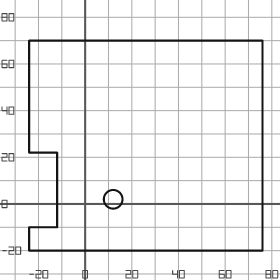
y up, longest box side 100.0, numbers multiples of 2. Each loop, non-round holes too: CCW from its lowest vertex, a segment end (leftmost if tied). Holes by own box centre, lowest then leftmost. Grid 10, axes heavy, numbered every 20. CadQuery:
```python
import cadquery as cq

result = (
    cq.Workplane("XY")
    .moveTo(-24.0, -20.0)
    .lineTo(76.0, -20.0)
    .lineTo(76.0, 70.0)
    .lineTo(-24.0, 70.0)
    .lineTo(-24.0, 22.0)
    .lineTo(-12.0, 22.0)
    .lineTo(-12.0, -10.0)
    .lineTo(-24.0, -10.0)
    .close()
    .moveTo(12.0, 2.0)
    .circle(4.0)
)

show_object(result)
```